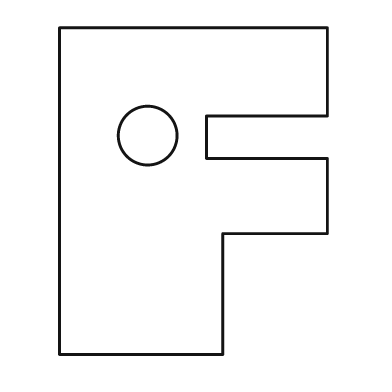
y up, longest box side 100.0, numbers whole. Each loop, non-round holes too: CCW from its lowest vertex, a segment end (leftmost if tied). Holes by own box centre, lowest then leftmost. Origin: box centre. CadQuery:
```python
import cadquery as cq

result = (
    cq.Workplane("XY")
    .moveTo(-41.0, -50.0)
    .lineTo(9.0, -50.0)
    .lineTo(9.0, -13.0)
    .lineTo(41.0, -13.0)
    .lineTo(41.0, 10.0)
    .lineTo(4.0, 10.0)
    .lineTo(4.0, 23.0)
    .lineTo(41.0, 23.0)
    .lineTo(41.0, 50.0)
    .lineTo(-41.0, 50.0)
    .close()
    .moveTo(-14.0, 17.0)
    .circle(9.0)
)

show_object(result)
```